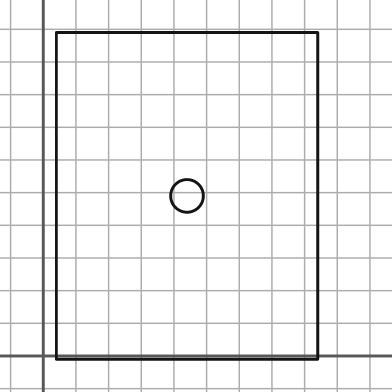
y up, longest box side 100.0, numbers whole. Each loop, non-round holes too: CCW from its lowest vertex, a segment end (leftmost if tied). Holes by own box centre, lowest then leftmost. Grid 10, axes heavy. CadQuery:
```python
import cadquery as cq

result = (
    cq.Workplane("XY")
    .moveTo(4.0, -1.0)
    .lineTo(84.0, -1.0)
    .lineTo(84.0, 99.0)
    .lineTo(4.0, 99.0)
    .close()
    .moveTo(44.0, 49.0)
    .circle(5.0)
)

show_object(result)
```